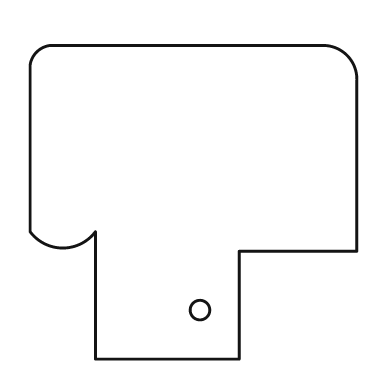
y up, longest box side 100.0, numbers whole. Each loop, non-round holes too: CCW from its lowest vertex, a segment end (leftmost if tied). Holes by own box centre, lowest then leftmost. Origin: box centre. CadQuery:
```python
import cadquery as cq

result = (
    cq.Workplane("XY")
    .moveTo(-30.0, -48.0)
    .lineTo(14.0, -48.0)
    .lineTo(14.0, -15.0)
    .lineTo(50.0, -15.0)
    .lineTo(50.0, 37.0)
    .threePointArc((47.0, 45.0), (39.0, 48.0))
    .lineTo(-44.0, 48.0)
    .threePointArc((-48.0, 46.0), (-50.0, 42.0))
    .lineTo(-50.0, -9.0)
    .threePointArc((-40.0, -14.0), (-30.0, -9.0))
    .close()
    .moveTo(2.0, -33.0)
    .circle(3.0)
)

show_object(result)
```